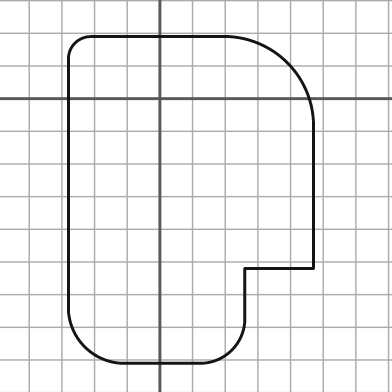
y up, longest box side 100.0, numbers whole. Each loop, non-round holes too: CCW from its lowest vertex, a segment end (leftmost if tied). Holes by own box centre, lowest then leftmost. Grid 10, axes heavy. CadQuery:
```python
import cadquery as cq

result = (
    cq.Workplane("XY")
    .moveTo(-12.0, -81.0)
    .lineTo(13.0, -81.0)
    .threePointArc((22.0, -77.0), (26.0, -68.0))
    .lineTo(26.0, -52.0)
    .lineTo(47.0, -52.0)
    .lineTo(47.0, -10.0)
    .threePointArc((39.0, 11.0), (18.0, 19.0))
    .lineTo(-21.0, 19.0)
    .threePointArc((-26.0, 17.0), (-28.0, 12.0))
    .lineTo(-28.0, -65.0)
    .threePointArc((-23.0, -76.0), (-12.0, -81.0))
    .close()
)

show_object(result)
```